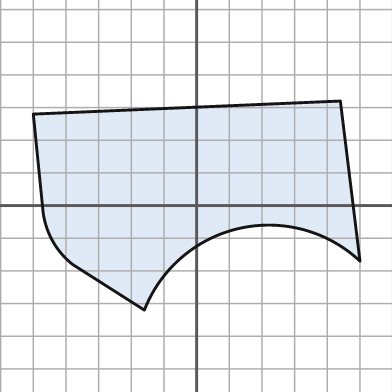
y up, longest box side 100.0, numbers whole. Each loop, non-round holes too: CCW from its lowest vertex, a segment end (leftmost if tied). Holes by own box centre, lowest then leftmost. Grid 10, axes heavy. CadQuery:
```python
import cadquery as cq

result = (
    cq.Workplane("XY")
    .moveTo(-16.0, -32.0)
    .threePointArc((13.0, -7.0), (50.0, -17.0))
    .lineTo(44.0, 32.0)
    .lineTo(-50.0, 28.0)
    .lineTo(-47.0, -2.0)
    .threePointArc((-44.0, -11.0), (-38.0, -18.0))
    .close()
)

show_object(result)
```